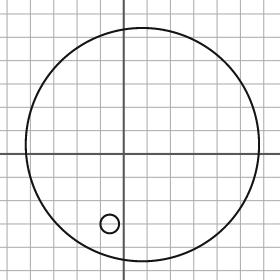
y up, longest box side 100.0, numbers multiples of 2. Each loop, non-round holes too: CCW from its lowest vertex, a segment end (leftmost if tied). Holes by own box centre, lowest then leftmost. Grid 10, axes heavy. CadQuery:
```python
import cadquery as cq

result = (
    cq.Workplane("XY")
    .moveTo(8.0, 4.0)
    .circle(50.0)
    .moveTo(-6.0, -30.0)
    .circle(4.0)
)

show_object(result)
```